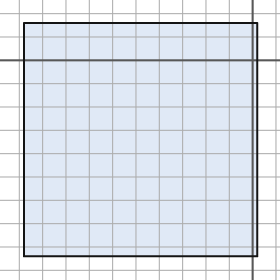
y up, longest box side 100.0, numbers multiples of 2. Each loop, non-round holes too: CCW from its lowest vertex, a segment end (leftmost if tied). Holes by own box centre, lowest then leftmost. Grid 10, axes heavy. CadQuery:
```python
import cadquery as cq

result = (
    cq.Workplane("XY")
    .moveTo(-98.0, -84.0)
    .lineTo(2.0, -84.0)
    .lineTo(2.0, 16.0)
    .lineTo(-98.0, 16.0)
    .close()
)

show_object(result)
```